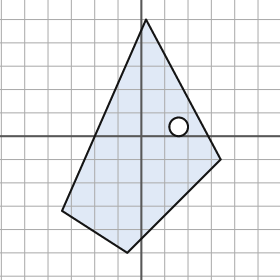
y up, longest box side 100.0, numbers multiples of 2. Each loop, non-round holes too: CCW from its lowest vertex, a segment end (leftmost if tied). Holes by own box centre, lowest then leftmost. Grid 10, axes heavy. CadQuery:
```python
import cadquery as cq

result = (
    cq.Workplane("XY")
    .moveTo(-6.0, -50.0)
    .lineTo(34.0, -10.0)
    .lineTo(2.0, 50.0)
    .lineTo(-34.0, -32.0)
    .close()
    .moveTo(16.0, 4.0)
    .circle(4.0)
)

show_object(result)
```